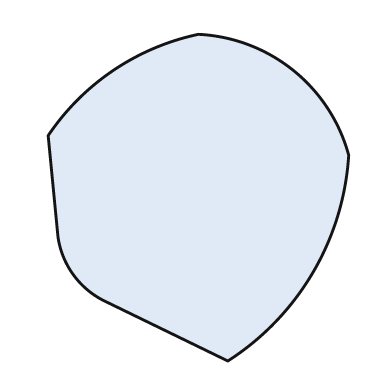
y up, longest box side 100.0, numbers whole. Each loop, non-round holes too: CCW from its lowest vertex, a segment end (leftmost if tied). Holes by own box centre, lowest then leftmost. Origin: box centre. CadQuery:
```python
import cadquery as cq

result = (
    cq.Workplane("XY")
    .moveTo(9.0, -50.0)
    .threePointArc((35.0, -23.0), (46.0, 13.0))
    .threePointArc((29.0, 39.0), (0.0, 50.0))
    .threePointArc((-26.0, 39.0), (-46.0, 19.0))
    .lineTo(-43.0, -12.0)
    .threePointArc((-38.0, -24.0), (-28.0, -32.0))
    .close()
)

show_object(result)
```